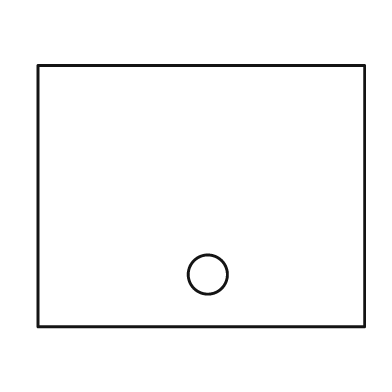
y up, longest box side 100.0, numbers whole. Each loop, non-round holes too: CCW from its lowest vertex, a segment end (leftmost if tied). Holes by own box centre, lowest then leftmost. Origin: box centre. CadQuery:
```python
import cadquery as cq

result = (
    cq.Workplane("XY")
    .moveTo(-50.0, -40.0)
    .lineTo(50.0, -40.0)
    .lineTo(50.0, 40.0)
    .lineTo(-50.0, 40.0)
    .close()
    .moveTo(2.0, -24.0)
    .circle(6.0)
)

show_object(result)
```